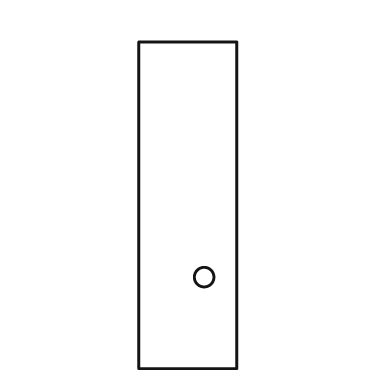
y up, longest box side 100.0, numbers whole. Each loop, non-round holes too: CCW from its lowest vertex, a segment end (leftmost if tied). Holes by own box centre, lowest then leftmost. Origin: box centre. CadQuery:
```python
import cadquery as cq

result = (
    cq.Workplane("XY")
    .moveTo(-15.0, -50.0)
    .lineTo(15.0, -50.0)
    .lineTo(15.0, 50.0)
    .lineTo(-15.0, 50.0)
    .close()
    .moveTo(5.0, -22.0)
    .circle(3.0)
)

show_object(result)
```